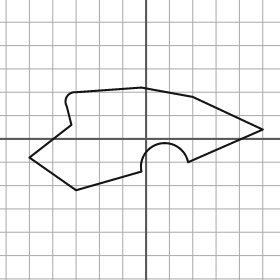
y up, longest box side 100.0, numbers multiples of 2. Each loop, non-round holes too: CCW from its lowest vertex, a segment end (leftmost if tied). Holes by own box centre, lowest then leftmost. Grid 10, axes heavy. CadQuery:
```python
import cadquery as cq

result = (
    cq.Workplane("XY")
    .moveTo(-30.0, -22.0)
    .lineTo(-2.0, -14.0)
    .threePointArc((6.0, -2.0), (18.0, -10.0))
    .lineTo(50.0, 4.0)
    .lineTo(20.0, 18.0)
    .lineTo(-2.0, 22.0)
    .lineTo(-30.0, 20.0)
    .threePointArc((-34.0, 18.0), (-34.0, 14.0))
    .lineTo(-32.0, 6.0)
    .lineTo(-50.0, -8.0)
    .close()
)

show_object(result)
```